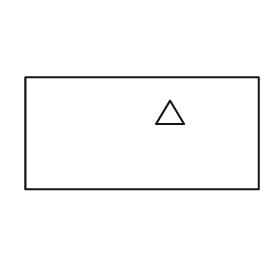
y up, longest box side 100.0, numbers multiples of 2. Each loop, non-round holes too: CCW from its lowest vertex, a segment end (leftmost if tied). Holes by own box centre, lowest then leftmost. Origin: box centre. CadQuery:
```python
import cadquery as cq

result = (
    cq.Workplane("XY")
    .moveTo(-50.0, -24.0)
    .lineTo(50.0, -24.0)
    .lineTo(50.0, 24.0)
    .lineTo(-50.0, 24.0)
    .close()
    .moveTo(6.0, 4.0)
    .lineTo(18.0, 4.0)
    .lineTo(12.0, 14.0)
    .close()
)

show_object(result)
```